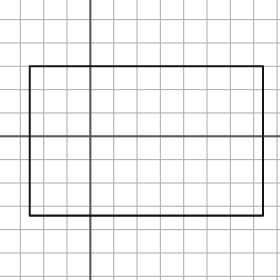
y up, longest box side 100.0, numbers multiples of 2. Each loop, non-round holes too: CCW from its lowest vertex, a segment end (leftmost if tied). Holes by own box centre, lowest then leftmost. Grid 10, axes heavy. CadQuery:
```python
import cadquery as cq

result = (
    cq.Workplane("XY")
    .moveTo(-26.0, -34.0)
    .lineTo(74.0, -34.0)
    .lineTo(74.0, 30.0)
    .lineTo(-26.0, 30.0)
    .close()
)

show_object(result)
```